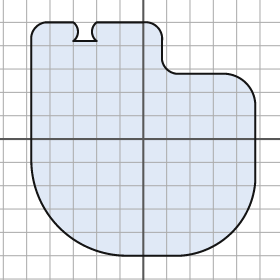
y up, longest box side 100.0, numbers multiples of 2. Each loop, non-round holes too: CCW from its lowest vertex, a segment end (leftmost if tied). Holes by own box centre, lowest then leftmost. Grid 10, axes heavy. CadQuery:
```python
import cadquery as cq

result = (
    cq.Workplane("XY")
    .moveTo(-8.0, -50.0)
    .lineTo(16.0, -50.0)
    .threePointArc((38.0, -40.0), (48.0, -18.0))
    .lineTo(48.0, 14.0)
    .threePointArc((44.0, 24.0), (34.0, 28.0))
    .lineTo(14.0, 28.0)
    .threePointArc((10.0, 30.0), (8.0, 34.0))
    .lineTo(8.0, 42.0)
    .threePointArc((6.0, 48.0), (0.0, 50.0))
    .lineTo(-20.0, 50.0)
    .threePointArc((-22.0, 46.0), (-20.0, 42.0))
    .lineTo(-30.0, 42.0)
    .threePointArc((-28.0, 46.0), (-30.0, 50.0))
    .lineTo(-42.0, 50.0)
    .threePointArc((-46.0, 48.0), (-48.0, 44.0))
    .lineTo(-48.0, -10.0)
    .threePointArc((-36.0, -38.0), (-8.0, -50.0))
    .close()
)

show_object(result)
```